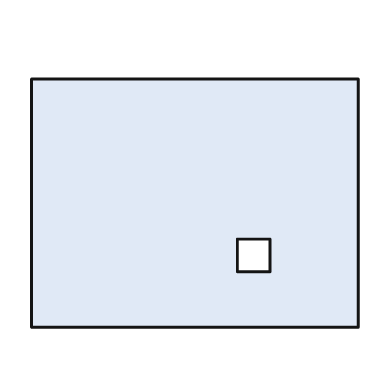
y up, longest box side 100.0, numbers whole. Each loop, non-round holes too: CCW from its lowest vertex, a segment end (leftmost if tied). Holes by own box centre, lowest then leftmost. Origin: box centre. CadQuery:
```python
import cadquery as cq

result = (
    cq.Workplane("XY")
    .moveTo(-50.0, -38.0)
    .lineTo(50.0, -38.0)
    .lineTo(50.0, 38.0)
    .lineTo(-50.0, 38.0)
    .close()
    .moveTo(13.0, -21.0)
    .lineTo(23.0, -21.0)
    .lineTo(23.0, -11.0)
    .lineTo(13.0, -11.0)
    .close()
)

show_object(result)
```